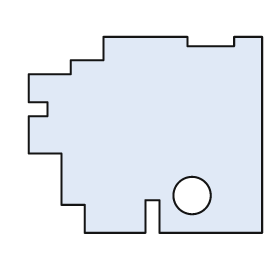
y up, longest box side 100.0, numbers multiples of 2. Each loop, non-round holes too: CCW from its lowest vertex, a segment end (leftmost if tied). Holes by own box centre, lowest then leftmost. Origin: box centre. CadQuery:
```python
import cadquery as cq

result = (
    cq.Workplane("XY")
    .moveTo(-26.0, -42.0)
    .lineTo(0.0, -42.0)
    .lineTo(0.0, -28.0)
    .lineTo(6.0, -28.0)
    .lineTo(6.0, -42.0)
    .lineTo(50.0, -42.0)
    .lineTo(50.0, 42.0)
    .lineTo(38.0, 42.0)
    .lineTo(38.0, 38.0)
    .lineTo(18.0, 38.0)
    .lineTo(18.0, 42.0)
    .lineTo(-18.0, 42.0)
    .lineTo(-18.0, 32.0)
    .lineTo(-32.0, 32.0)
    .lineTo(-32.0, 26.0)
    .lineTo(-50.0, 26.0)
    .lineTo(-50.0, 14.0)
    .lineTo(-42.0, 14.0)
    .lineTo(-42.0, 8.0)
    .lineTo(-50.0, 8.0)
    .lineTo(-50.0, -8.0)
    .lineTo(-36.0, -8.0)
    .lineTo(-36.0, -30.0)
    .lineTo(-26.0, -30.0)
    .close()
    .moveTo(20.0, -26.0)
    .circle(8.0)
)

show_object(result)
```